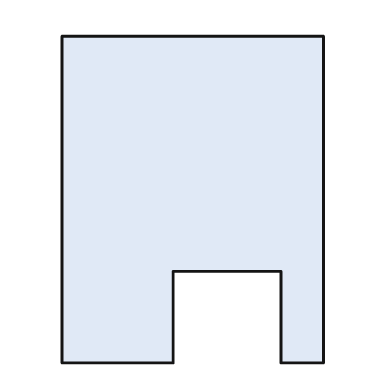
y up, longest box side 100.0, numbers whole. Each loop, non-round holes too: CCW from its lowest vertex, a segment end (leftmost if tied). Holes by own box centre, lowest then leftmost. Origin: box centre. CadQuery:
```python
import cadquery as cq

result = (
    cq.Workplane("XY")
    .moveTo(-40.0, -50.0)
    .lineTo(-6.0, -50.0)
    .lineTo(-6.0, -22.0)
    .lineTo(27.0, -22.0)
    .lineTo(27.0, -50.0)
    .lineTo(40.0, -50.0)
    .lineTo(40.0, 50.0)
    .lineTo(-40.0, 50.0)
    .close()
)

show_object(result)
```